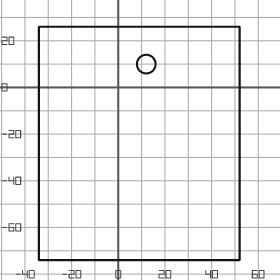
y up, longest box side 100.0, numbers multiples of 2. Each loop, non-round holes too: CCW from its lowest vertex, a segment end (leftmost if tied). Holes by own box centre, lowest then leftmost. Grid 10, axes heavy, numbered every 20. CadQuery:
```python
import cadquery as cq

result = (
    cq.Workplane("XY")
    .moveTo(-34.0, -74.0)
    .lineTo(52.0, -74.0)
    .lineTo(52.0, 26.0)
    .lineTo(-34.0, 26.0)
    .close()
    .moveTo(12.0, 10.0)
    .circle(4.0)
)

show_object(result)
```